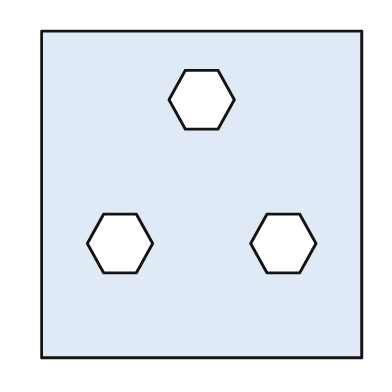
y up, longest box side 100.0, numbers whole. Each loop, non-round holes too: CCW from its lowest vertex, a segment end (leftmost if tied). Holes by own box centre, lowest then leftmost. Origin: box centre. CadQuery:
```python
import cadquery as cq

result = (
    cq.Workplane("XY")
    .moveTo(-49.0, -50.0)
    .lineTo(49.0, -50.0)
    .lineTo(49.0, 50.0)
    .lineTo(-49.0, 50.0)
    .close()
    .moveTo(-30.0, -24.0)
    .lineTo(-20.0, -24.0)
    .lineTo(-15.0, -15.0)
    .lineTo(-20.0, -6.0)
    .lineTo(-30.0, -6.0)
    .lineTo(-35.0, -15.0)
    .close()
    .moveTo(20.0, -24.0)
    .lineTo(30.0, -24.0)
    .lineTo(35.0, -15.0)
    .lineTo(30.0, -6.0)
    .lineTo(20.0, -6.0)
    .lineTo(15.0, -15.0)
    .close()
    .moveTo(-5.0, 20.0)
    .lineTo(5.0, 20.0)
    .lineTo(10.0, 29.0)
    .lineTo(5.0, 38.0)
    .lineTo(-5.0, 38.0)
    .lineTo(-10.0, 29.0)
    .close()
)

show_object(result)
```